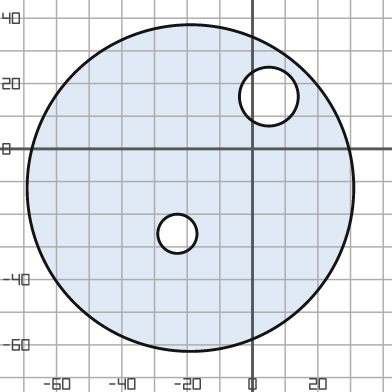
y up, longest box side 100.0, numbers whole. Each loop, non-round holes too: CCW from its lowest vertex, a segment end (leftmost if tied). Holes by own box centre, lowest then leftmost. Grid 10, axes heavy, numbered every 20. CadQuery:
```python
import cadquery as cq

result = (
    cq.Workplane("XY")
    .moveTo(-19.0, -12.0)
    .circle(50.0)
    .moveTo(-23.0, -26.0)
    .circle(6.0)
    .moveTo(5.0, 16.0)
    .circle(9.0)
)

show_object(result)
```